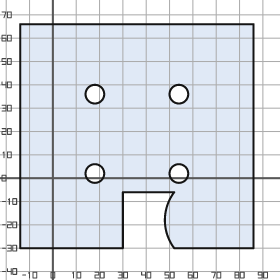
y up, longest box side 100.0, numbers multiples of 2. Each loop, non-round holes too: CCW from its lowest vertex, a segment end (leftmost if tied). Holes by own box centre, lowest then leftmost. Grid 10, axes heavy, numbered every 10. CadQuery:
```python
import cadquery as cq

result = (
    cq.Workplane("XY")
    .moveTo(-14.0, -30.0)
    .lineTo(30.0, -30.0)
    .lineTo(30.0, -6.0)
    .lineTo(52.0, -6.0)
    .threePointArc((48.0, -18.0), (52.0, -30.0))
    .lineTo(86.0, -30.0)
    .lineTo(86.0, 66.0)
    .lineTo(-14.0, 66.0)
    .close()
    .moveTo(18.0, 2.0)
    .circle(4.0)
    .moveTo(54.0, 2.0)
    .circle(4.0)
    .moveTo(18.0, 36.0)
    .circle(4.0)
    .moveTo(54.0, 36.0)
    .circle(4.0)
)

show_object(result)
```